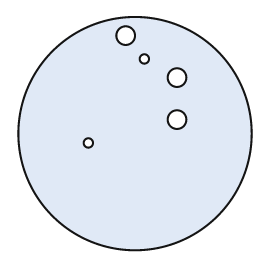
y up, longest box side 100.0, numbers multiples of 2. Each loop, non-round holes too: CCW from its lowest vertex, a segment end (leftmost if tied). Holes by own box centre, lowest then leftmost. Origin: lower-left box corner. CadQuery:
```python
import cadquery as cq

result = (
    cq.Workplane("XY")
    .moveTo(50.0, 50.0)
    .circle(50.0)
    .moveTo(30.0, 46.0)
    .circle(2.0)
    .moveTo(68.0, 56.0)
    .circle(4.0)
    .moveTo(68.0, 74.0)
    .circle(4.0)
    .moveTo(54.0, 82.0)
    .circle(2.0)
    .moveTo(46.0, 92.0)
    .circle(4.0)
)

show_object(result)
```